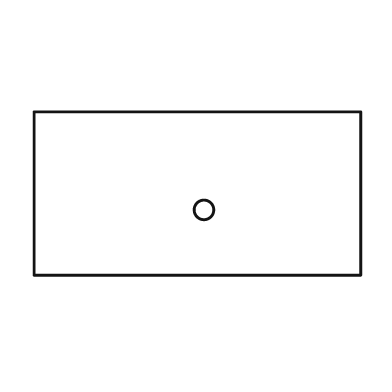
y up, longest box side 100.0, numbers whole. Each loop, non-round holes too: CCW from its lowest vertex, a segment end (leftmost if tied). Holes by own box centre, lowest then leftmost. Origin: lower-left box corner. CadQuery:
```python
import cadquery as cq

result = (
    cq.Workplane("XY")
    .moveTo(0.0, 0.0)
    .lineTo(100.0, 0.0)
    .lineTo(100.0, 50.0)
    .lineTo(0.0, 50.0)
    .close()
    .moveTo(52.0, 20.0)
    .circle(3.0)
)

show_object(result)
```